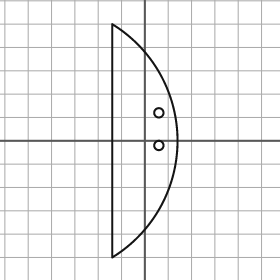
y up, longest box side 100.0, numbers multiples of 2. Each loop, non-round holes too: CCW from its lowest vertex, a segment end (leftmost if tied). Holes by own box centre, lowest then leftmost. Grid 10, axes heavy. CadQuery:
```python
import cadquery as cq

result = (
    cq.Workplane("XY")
    .moveTo(-14.0, -50.0)
    .threePointArc((14.0, 0.0), (-14.0, 50.0))
    .close()
    .moveTo(6.0, -2.0)
    .circle(2.0)
    .moveTo(6.0, 12.0)
    .circle(2.0)
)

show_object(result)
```